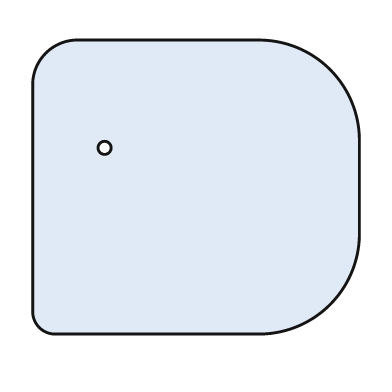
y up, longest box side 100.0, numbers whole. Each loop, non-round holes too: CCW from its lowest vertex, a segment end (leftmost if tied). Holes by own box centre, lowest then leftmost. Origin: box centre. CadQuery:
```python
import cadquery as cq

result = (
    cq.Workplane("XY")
    .moveTo(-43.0, -45.0)
    .lineTo(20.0, -45.0)
    .threePointArc((41.0, -36.0), (50.0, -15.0))
    .lineTo(50.0, 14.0)
    .threePointArc((41.0, 36.0), (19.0, 45.0))
    .lineTo(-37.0, 45.0)
    .threePointArc((-46.0, 41.0), (-50.0, 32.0))
    .lineTo(-50.0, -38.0)
    .threePointArc((-48.0, -43.0), (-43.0, -45.0))
    .close()
    .moveTo(-28.0, 12.0)
    .circle(2.0)
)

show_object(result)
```